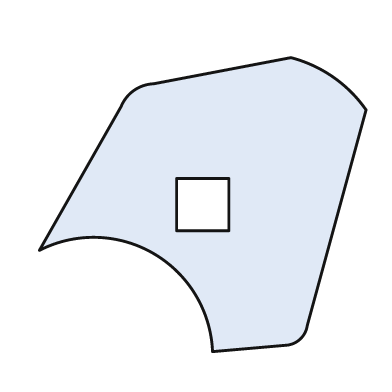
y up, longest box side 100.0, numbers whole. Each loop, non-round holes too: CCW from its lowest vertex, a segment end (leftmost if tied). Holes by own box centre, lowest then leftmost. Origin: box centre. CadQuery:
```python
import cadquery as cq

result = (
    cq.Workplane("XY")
    .moveTo(3.0, -45.0)
    .lineTo(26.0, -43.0)
    .threePointArc((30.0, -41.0), (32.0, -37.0))
    .lineTo(50.0, 29.0)
    .threePointArc((40.0, 39.0), (27.0, 45.0))
    .lineTo(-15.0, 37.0)
    .threePointArc((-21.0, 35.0), (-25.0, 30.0))
    .lineTo(-50.0, -14.0)
    .threePointArc((-15.0, -15.0), (3.0, -45.0))
    .close()
    .moveTo(-8.0, -8.0)
    .lineTo(8.0, -8.0)
    .lineTo(8.0, 8.0)
    .lineTo(-8.0, 8.0)
    .close()
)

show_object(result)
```